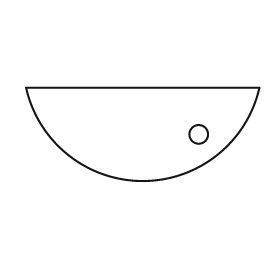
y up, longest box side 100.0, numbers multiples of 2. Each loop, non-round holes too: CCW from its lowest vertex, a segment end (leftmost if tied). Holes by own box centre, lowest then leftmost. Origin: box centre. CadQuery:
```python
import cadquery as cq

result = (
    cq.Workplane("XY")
    .moveTo(-50.0, 20.0)
    .threePointArc((0.0, -20.0), (50.0, 20.0))
    .close()
    .moveTo(24.0, 0.0)
    .circle(4.0)
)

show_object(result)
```